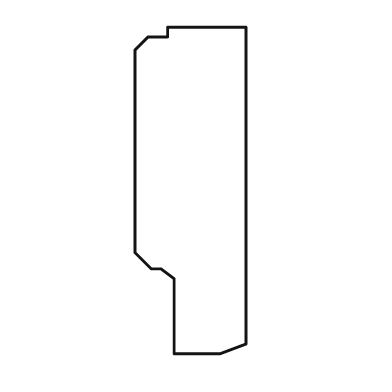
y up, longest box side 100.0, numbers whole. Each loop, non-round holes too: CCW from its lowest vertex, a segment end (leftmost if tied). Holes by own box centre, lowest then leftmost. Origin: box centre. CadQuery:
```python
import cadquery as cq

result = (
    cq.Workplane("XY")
    .moveTo(-5.0, -50.0)
    .lineTo(9.0, -50.0)
    .lineTo(17.0, -47.0)
    .lineTo(17.0, 50.0)
    .lineTo(-7.0, 50.0)
    .lineTo(-7.0, 47.0)
    .lineTo(-13.0, 47.0)
    .lineTo(-17.0, 43.0)
    .lineTo(-17.0, -19.0)
    .lineTo(-12.0, -24.0)
    .lineTo(-9.0, -24.0)
    .lineTo(-5.0, -27.0)
    .close()
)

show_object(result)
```